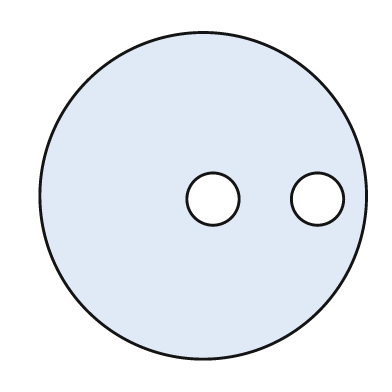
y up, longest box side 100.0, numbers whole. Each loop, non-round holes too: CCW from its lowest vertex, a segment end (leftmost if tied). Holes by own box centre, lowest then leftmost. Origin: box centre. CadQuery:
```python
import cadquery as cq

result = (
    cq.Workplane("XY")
    .moveTo(0.0, 0.0)
    .circle(50.0)
    .moveTo(3.0, -1.0)
    .circle(8.0)
    .moveTo(35.0, -1.0)
    .circle(8.0)
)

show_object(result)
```